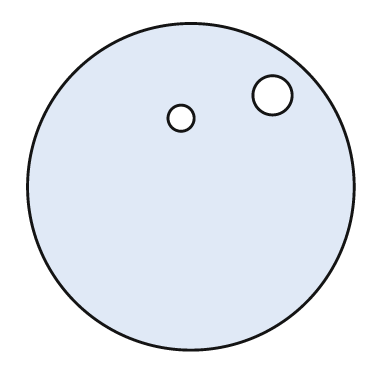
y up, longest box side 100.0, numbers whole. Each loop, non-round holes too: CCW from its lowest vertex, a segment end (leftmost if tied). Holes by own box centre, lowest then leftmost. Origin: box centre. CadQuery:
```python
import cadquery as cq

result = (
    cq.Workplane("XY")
    .moveTo(0.0, 0.0)
    .circle(50.0)
    .moveTo(-3.0, 21.0)
    .circle(4.0)
    .moveTo(25.0, 28.0)
    .circle(6.0)
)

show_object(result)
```